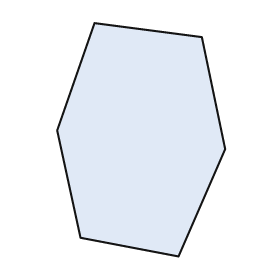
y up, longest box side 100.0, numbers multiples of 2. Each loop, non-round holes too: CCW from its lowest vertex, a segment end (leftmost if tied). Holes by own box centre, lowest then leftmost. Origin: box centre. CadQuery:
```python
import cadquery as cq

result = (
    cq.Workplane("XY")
    .moveTo(16.0, -50.0)
    .lineTo(36.0, -4.0)
    .lineTo(26.0, 44.0)
    .lineTo(-20.0, 50.0)
    .lineTo(-36.0, 4.0)
    .lineTo(-26.0, -42.0)
    .close()
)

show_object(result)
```